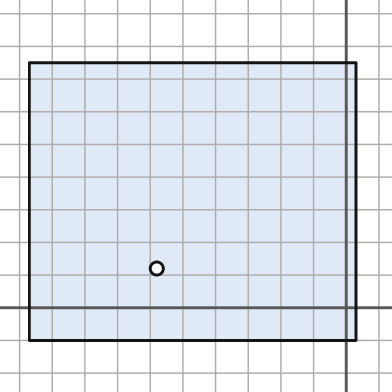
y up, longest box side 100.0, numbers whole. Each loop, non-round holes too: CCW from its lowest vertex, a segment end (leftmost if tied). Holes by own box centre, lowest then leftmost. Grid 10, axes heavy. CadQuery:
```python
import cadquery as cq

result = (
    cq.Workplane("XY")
    .moveTo(-97.0, -10.0)
    .lineTo(3.0, -10.0)
    .lineTo(3.0, 75.0)
    .lineTo(-97.0, 75.0)
    .close()
    .moveTo(-58.0, 12.0)
    .circle(2.0)
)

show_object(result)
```